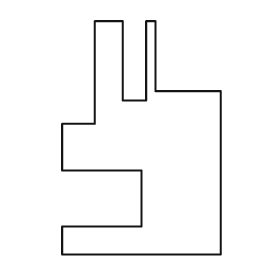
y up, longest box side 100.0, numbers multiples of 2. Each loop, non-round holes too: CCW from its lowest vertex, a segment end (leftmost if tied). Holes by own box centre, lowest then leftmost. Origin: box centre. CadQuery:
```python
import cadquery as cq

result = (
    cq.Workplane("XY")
    .moveTo(-34.0, -50.0)
    .lineTo(34.0, -50.0)
    .lineTo(34.0, 20.0)
    .lineTo(6.0, 20.0)
    .lineTo(6.0, 50.0)
    .lineTo(2.0, 50.0)
    .lineTo(2.0, 16.0)
    .lineTo(-8.0, 16.0)
    .lineTo(-8.0, 50.0)
    .lineTo(-20.0, 50.0)
    .lineTo(-20.0, 6.0)
    .lineTo(-34.0, 6.0)
    .lineTo(-34.0, -14.0)
    .lineTo(0.0, -14.0)
    .lineTo(0.0, -38.0)
    .lineTo(-34.0, -38.0)
    .close()
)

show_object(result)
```